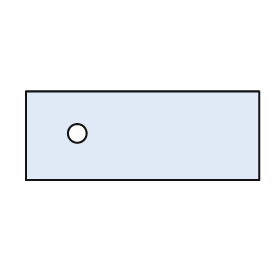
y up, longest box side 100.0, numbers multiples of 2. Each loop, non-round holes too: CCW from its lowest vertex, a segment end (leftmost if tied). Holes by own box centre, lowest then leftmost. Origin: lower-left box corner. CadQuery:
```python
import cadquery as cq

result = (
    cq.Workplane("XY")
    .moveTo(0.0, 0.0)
    .lineTo(100.0, 0.0)
    .lineTo(100.0, 38.0)
    .lineTo(0.0, 38.0)
    .close()
    .moveTo(22.0, 20.0)
    .circle(4.0)
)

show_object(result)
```